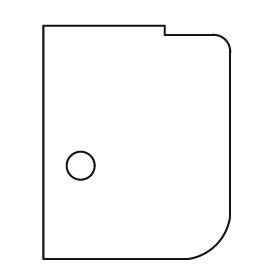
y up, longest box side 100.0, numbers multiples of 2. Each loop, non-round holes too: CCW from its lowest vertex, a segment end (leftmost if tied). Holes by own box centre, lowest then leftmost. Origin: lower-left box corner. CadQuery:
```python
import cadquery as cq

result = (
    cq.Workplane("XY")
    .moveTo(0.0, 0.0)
    .lineTo(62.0, 0.0)
    .threePointArc((74.0, 6.0), (80.0, 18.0))
    .lineTo(80.0, 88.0)
    .threePointArc((78.0, 94.0), (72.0, 96.0))
    .lineTo(52.0, 96.0)
    .lineTo(52.0, 100.0)
    .lineTo(0.0, 100.0)
    .close()
    .moveTo(16.0, 40.0)
    .circle(6.0)
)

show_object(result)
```